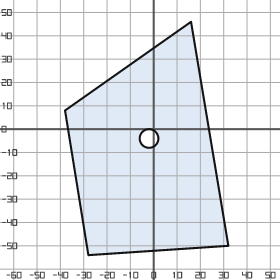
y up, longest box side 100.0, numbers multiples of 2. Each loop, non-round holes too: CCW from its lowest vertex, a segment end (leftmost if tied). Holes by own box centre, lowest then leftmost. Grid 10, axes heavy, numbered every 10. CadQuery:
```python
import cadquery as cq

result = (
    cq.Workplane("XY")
    .moveTo(-28.0, -54.0)
    .lineTo(32.0, -50.0)
    .lineTo(16.0, 46.0)
    .lineTo(-38.0, 8.0)
    .close()
    .moveTo(-2.0, -4.0)
    .circle(4.0)
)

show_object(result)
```